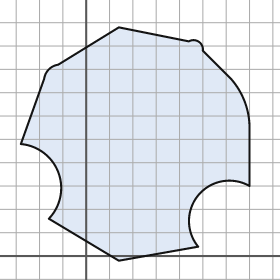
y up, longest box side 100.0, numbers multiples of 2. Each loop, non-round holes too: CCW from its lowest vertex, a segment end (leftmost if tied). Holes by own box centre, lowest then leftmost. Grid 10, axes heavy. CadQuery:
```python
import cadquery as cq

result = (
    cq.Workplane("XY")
    .moveTo(14.0, -2.0)
    .lineTo(48.0, 4.0)
    .threePointArc((48.0, 26.0), (70.0, 30.0))
    .lineTo(70.0, 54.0)
    .threePointArc((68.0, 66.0), (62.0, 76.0))
    .lineTo(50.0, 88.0)
    .threePointArc((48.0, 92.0), (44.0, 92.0))
    .lineTo(14.0, 98.0)
    .lineTo(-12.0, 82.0)
    .threePointArc((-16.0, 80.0), (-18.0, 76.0))
    .lineTo(-28.0, 48.0)
    .threePointArc((-12.0, 36.0), (-16.0, 16.0))
    .close()
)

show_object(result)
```